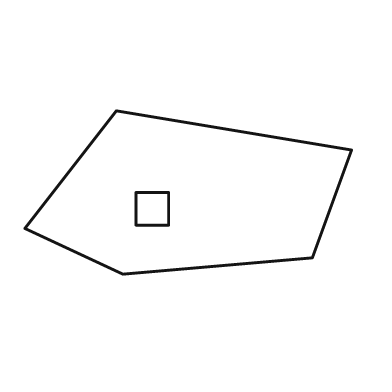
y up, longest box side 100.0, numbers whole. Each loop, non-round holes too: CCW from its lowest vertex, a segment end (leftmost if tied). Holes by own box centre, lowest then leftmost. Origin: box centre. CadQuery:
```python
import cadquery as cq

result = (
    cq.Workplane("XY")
    .moveTo(-20.0, -25.0)
    .lineTo(38.0, -20.0)
    .lineTo(50.0, 13.0)
    .lineTo(-22.0, 25.0)
    .lineTo(-50.0, -11.0)
    .close()
    .moveTo(-16.0, -10.0)
    .lineTo(-6.0, -10.0)
    .lineTo(-6.0, 0.0)
    .lineTo(-16.0, 0.0)
    .close()
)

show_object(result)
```